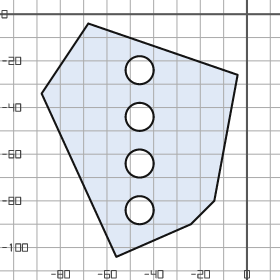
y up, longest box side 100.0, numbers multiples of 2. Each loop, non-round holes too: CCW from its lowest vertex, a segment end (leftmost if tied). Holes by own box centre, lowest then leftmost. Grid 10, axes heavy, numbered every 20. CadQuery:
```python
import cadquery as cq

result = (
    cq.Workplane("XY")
    .moveTo(-56.0, -104.0)
    .lineTo(-24.0, -90.0)
    .lineTo(-14.0, -80.0)
    .lineTo(-4.0, -26.0)
    .lineTo(-68.0, -4.0)
    .lineTo(-88.0, -34.0)
    .close()
    .moveTo(-46.0, -84.0)
    .circle(6.0)
    .moveTo(-46.0, -64.0)
    .circle(6.0)
    .moveTo(-46.0, -44.0)
    .circle(6.0)
    .moveTo(-46.0, -24.0)
    .circle(6.0)
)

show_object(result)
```